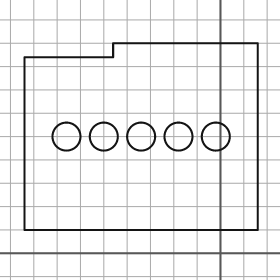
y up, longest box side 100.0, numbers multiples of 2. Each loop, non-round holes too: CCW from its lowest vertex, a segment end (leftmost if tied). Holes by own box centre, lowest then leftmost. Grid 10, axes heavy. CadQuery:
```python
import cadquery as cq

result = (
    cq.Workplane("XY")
    .moveTo(-84.0, 10.0)
    .lineTo(16.0, 10.0)
    .lineTo(16.0, 90.0)
    .lineTo(-46.0, 90.0)
    .lineTo(-46.0, 84.0)
    .lineTo(-84.0, 84.0)
    .close()
    .moveTo(-66.0, 50.0)
    .circle(6.0)
    .moveTo(-50.0, 50.0)
    .circle(6.0)
    .moveTo(-34.0, 50.0)
    .circle(6.0)
    .moveTo(-18.0, 50.0)
    .circle(6.0)
    .moveTo(-2.0, 50.0)
    .circle(6.0)
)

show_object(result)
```